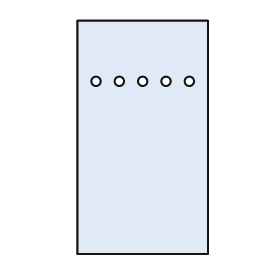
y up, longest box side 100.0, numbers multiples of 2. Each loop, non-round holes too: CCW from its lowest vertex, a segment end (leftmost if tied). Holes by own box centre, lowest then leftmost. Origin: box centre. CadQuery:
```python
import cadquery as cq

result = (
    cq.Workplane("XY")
    .moveTo(-28.0, -50.0)
    .lineTo(28.0, -50.0)
    .lineTo(28.0, 50.0)
    .lineTo(-28.0, 50.0)
    .close()
    .moveTo(-20.0, 24.0)
    .circle(2.0)
    .moveTo(-10.0, 24.0)
    .circle(2.0)
    .moveTo(0.0, 24.0)
    .circle(2.0)
    .moveTo(10.0, 24.0)
    .circle(2.0)
    .moveTo(20.0, 24.0)
    .circle(2.0)
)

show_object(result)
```